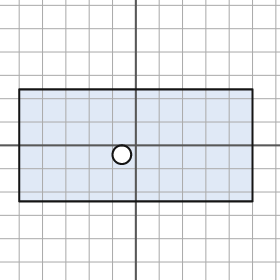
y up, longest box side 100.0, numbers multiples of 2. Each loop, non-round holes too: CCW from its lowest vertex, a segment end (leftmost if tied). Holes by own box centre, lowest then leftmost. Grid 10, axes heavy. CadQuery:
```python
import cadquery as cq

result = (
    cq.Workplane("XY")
    .moveTo(-50.0, -24.0)
    .lineTo(50.0, -24.0)
    .lineTo(50.0, 24.0)
    .lineTo(-50.0, 24.0)
    .close()
    .moveTo(-6.0, -4.0)
    .circle(4.0)
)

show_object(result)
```